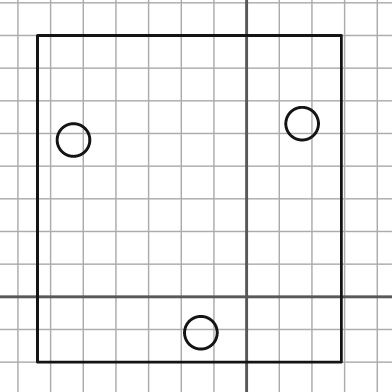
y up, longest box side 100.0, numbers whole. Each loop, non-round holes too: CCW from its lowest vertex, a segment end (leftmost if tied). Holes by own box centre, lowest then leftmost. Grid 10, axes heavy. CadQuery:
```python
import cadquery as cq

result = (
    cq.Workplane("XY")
    .moveTo(-64.0, -20.0)
    .lineTo(29.0, -20.0)
    .lineTo(29.0, 80.0)
    .lineTo(-64.0, 80.0)
    .close()
    .moveTo(-14.0, -11.0)
    .circle(5.0)
    .moveTo(-53.0, 48.0)
    .circle(5.0)
    .moveTo(17.0, 53.0)
    .circle(5.0)
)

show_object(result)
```